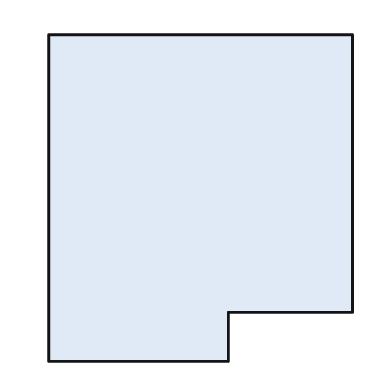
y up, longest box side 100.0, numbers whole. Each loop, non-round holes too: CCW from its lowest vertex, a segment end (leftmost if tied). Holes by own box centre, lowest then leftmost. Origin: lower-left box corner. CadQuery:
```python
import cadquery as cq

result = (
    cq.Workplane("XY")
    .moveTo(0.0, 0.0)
    .lineTo(55.0, 0.0)
    .lineTo(55.0, 15.0)
    .lineTo(93.0, 15.0)
    .lineTo(93.0, 100.0)
    .lineTo(0.0, 100.0)
    .close()
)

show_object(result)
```